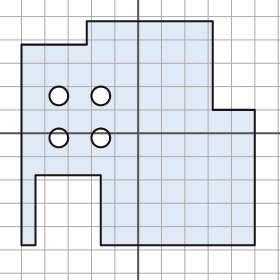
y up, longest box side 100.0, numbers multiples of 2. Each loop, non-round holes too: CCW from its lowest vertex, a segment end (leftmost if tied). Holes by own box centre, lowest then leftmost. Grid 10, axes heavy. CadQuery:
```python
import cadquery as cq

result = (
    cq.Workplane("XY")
    .moveTo(-50.0, -48.0)
    .lineTo(-44.0, -48.0)
    .lineTo(-44.0, -18.0)
    .lineTo(-16.0, -18.0)
    .lineTo(-16.0, -48.0)
    .lineTo(50.0, -48.0)
    .lineTo(50.0, 10.0)
    .lineTo(32.0, 10.0)
    .lineTo(32.0, 48.0)
    .lineTo(-22.0, 48.0)
    .lineTo(-22.0, 38.0)
    .lineTo(-50.0, 38.0)
    .close()
    .moveTo(-34.0, -2.0)
    .circle(4.0)
    .moveTo(-16.0, -2.0)
    .circle(4.0)
    .moveTo(-34.0, 16.0)
    .circle(4.0)
    .moveTo(-16.0, 16.0)
    .circle(4.0)
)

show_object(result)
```